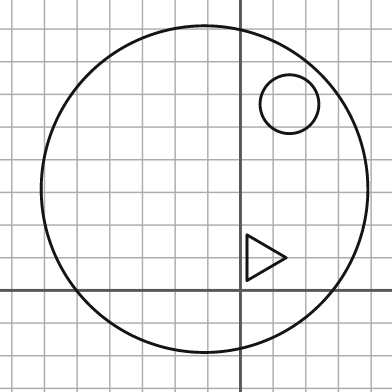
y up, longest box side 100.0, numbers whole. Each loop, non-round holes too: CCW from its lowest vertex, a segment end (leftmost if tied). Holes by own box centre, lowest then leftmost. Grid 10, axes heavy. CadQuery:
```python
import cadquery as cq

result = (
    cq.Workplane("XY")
    .moveTo(-11.0, 31.0)
    .circle(50.0)
    .moveTo(2.0, 3.0)
    .lineTo(14.0, 10.0)
    .lineTo(2.0, 17.0)
    .close()
    .moveTo(15.0, 57.0)
    .circle(9.0)
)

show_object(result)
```